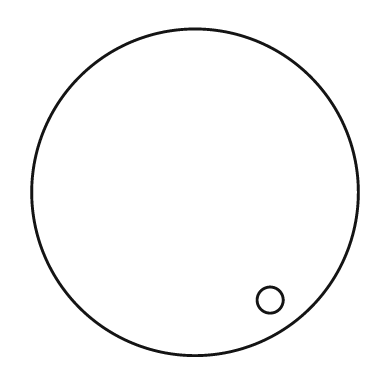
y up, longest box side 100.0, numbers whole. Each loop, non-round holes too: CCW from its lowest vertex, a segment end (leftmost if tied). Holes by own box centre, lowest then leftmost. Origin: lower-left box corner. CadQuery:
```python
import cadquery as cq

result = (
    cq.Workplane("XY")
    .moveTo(50.0, 50.0)
    .circle(50.0)
    .moveTo(73.0, 17.0)
    .circle(4.0)
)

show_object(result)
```